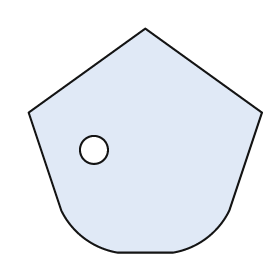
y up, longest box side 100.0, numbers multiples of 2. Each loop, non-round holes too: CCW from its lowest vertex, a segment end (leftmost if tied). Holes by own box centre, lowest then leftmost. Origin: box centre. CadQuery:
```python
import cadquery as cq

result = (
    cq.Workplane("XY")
    .moveTo(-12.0, -48.0)
    .lineTo(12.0, -48.0)
    .threePointArc((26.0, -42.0), (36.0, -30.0))
    .lineTo(50.0, 12.0)
    .lineTo(0.0, 48.0)
    .lineTo(-50.0, 12.0)
    .lineTo(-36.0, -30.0)
    .threePointArc((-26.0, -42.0), (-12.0, -48.0))
    .close()
    .moveTo(-22.0, -4.0)
    .circle(6.0)
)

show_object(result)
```